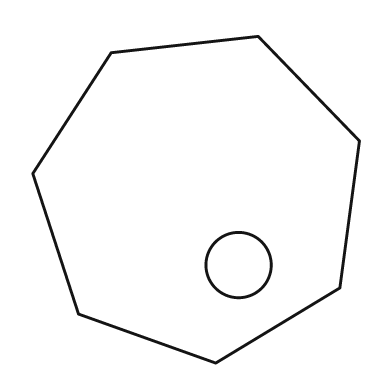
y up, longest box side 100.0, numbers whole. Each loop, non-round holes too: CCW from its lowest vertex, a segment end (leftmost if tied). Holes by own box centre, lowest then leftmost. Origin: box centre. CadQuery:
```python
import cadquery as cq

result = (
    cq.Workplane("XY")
    .moveTo(6.0, -50.0)
    .lineTo(44.0, -27.0)
    .lineTo(50.0, 18.0)
    .lineTo(19.0, 50.0)
    .lineTo(-26.0, 45.0)
    .lineTo(-50.0, 8.0)
    .lineTo(-36.0, -35.0)
    .close()
    .moveTo(13.0, -20.0)
    .circle(10.0)
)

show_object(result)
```